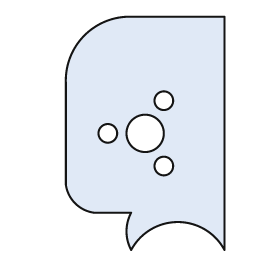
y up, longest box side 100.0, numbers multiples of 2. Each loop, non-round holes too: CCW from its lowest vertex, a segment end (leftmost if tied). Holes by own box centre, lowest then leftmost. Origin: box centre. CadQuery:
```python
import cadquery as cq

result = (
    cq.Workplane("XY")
    .moveTo(-6.0, -50.0)
    .threePointArc((14.0, -38.0), (34.0, -50.0))
    .lineTo(34.0, 50.0)
    .lineTo(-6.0, 50.0)
    .threePointArc((-26.0, 42.0), (-34.0, 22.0))
    .lineTo(-34.0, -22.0)
    .threePointArc((-30.0, -30.0), (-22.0, -34.0))
    .lineTo(-6.0, -34.0)
    .threePointArc((-8.0, -42.0), (-6.0, -50.0))
    .close()
    .moveTo(8.0, -14.0)
    .circle(4.0)
    .moveTo(-16.0, 0.0)
    .circle(4.0)
    .moveTo(0.0, 0.0)
    .circle(8.0)
    .moveTo(8.0, 14.0)
    .circle(4.0)
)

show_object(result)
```